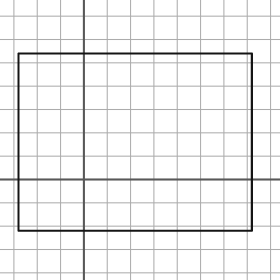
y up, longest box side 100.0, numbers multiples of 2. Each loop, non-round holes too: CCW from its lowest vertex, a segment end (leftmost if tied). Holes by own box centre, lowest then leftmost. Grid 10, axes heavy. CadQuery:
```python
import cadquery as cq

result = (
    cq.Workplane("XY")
    .moveTo(-28.0, -22.0)
    .lineTo(72.0, -22.0)
    .lineTo(72.0, 54.0)
    .lineTo(-28.0, 54.0)
    .close()
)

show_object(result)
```